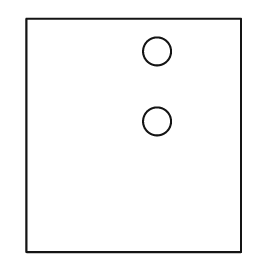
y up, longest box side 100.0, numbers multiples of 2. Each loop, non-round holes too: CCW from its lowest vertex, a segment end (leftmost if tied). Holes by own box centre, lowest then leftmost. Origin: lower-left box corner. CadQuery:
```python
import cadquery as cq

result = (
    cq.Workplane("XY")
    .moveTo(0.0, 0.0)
    .lineTo(92.0, 0.0)
    .lineTo(92.0, 100.0)
    .lineTo(0.0, 100.0)
    .close()
    .moveTo(56.0, 56.0)
    .circle(6.0)
    .moveTo(56.0, 86.0)
    .circle(6.0)
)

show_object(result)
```